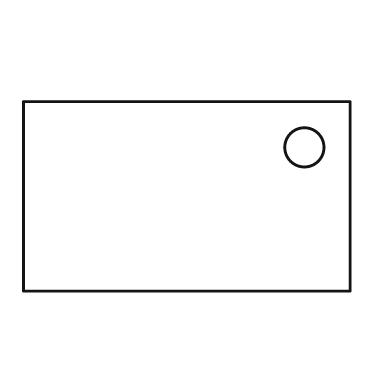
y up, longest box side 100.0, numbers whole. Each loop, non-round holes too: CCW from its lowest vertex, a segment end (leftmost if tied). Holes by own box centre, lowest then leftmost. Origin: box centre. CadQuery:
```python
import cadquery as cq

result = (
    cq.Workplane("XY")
    .moveTo(-50.0, -29.0)
    .lineTo(50.0, -29.0)
    .lineTo(50.0, 29.0)
    .lineTo(-50.0, 29.0)
    .close()
    .moveTo(36.0, 15.0)
    .circle(6.0)
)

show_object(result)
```